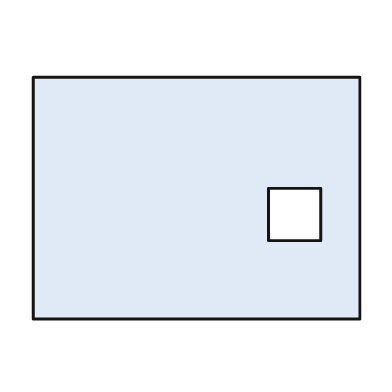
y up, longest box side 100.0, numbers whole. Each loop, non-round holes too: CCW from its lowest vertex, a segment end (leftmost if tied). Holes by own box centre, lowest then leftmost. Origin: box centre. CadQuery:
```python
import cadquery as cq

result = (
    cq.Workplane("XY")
    .moveTo(-50.0, -37.0)
    .lineTo(50.0, -37.0)
    .lineTo(50.0, 37.0)
    .lineTo(-50.0, 37.0)
    .close()
    .moveTo(22.0, -13.0)
    .lineTo(38.0, -13.0)
    .lineTo(38.0, 3.0)
    .lineTo(22.0, 3.0)
    .close()
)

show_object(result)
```